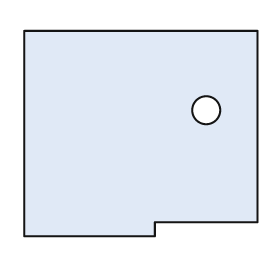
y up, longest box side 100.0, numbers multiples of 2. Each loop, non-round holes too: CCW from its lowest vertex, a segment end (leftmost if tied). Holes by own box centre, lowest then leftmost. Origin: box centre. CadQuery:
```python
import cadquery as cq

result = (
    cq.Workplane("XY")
    .moveTo(-50.0, -44.0)
    .lineTo(6.0, -44.0)
    .lineTo(6.0, -38.0)
    .lineTo(50.0, -38.0)
    .lineTo(50.0, 44.0)
    .lineTo(-50.0, 44.0)
    .close()
    .moveTo(28.0, 10.0)
    .circle(6.0)
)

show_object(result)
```